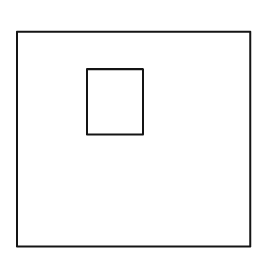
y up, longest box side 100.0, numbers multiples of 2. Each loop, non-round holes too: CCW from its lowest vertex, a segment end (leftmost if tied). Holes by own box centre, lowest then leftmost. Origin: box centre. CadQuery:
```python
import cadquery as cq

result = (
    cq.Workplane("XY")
    .moveTo(-50.0, -46.0)
    .lineTo(50.0, -46.0)
    .lineTo(50.0, 46.0)
    .lineTo(-50.0, 46.0)
    .close()
    .moveTo(-20.0, 2.0)
    .lineTo(4.0, 2.0)
    .lineTo(4.0, 30.0)
    .lineTo(-20.0, 30.0)
    .close()
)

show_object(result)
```